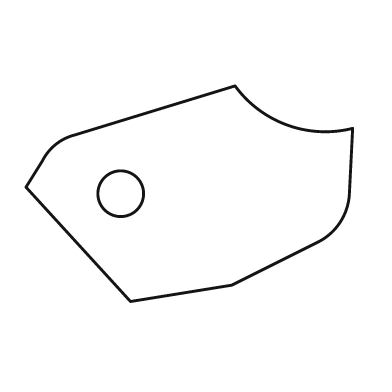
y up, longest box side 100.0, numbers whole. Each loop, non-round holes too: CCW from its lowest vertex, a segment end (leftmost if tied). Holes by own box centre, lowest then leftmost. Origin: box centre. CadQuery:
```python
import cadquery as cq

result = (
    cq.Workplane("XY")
    .moveTo(-18.0, -33.0)
    .lineTo(13.0, -28.0)
    .lineTo(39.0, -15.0)
    .threePointArc((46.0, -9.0), (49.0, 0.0))
    .lineTo(50.0, 20.0)
    .threePointArc((30.0, 21.0), (14.0, 33.0))
    .lineTo(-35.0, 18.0)
    .threePointArc((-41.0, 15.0), (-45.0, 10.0))
    .lineTo(-50.0, 2.0)
    .close()
    .moveTo(-21.0, 0.0)
    .circle(7.0)
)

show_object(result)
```